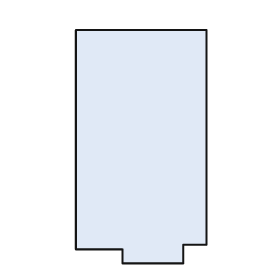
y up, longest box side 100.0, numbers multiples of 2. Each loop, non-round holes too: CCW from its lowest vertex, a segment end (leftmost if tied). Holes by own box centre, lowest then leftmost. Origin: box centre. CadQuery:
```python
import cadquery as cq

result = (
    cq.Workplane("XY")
    .moveTo(-8.0, -50.0)
    .lineTo(18.0, -50.0)
    .lineTo(18.0, -42.0)
    .lineTo(28.0, -42.0)
    .lineTo(28.0, 50.0)
    .lineTo(-28.0, 50.0)
    .lineTo(-28.0, -44.0)
    .lineTo(-8.0, -44.0)
    .close()
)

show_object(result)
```